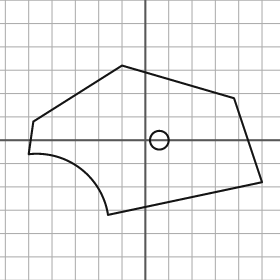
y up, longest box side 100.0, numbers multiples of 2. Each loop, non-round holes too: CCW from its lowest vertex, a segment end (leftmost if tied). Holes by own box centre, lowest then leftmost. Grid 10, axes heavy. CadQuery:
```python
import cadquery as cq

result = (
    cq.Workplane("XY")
    .moveTo(-16.0, -32.0)
    .lineTo(50.0, -18.0)
    .lineTo(38.0, 18.0)
    .lineTo(-10.0, 32.0)
    .lineTo(-48.0, 8.0)
    .lineTo(-50.0, -6.0)
    .threePointArc((-28.0, -12.0), (-16.0, -32.0))
    .close()
    .moveTo(6.0, 0.0)
    .circle(4.0)
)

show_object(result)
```